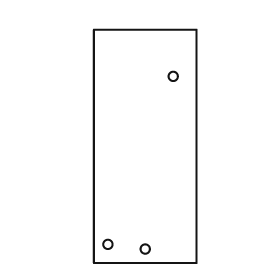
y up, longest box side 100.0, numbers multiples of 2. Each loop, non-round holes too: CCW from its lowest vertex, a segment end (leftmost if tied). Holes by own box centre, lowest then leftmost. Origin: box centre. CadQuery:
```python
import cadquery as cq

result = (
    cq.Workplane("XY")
    .moveTo(-22.0, -50.0)
    .lineTo(22.0, -50.0)
    .lineTo(22.0, 50.0)
    .lineTo(-22.0, 50.0)
    .close()
    .moveTo(0.0, -44.0)
    .circle(2.0)
    .moveTo(-16.0, -42.0)
    .circle(2.0)
    .moveTo(12.0, 30.0)
    .circle(2.0)
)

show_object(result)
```